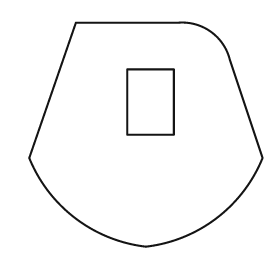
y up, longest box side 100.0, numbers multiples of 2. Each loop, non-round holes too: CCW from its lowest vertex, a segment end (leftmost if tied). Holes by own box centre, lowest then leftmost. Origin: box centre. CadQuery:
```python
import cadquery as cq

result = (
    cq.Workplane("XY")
    .moveTo(0.0, -48.0)
    .threePointArc((30.0, -36.0), (50.0, -10.0))
    .lineTo(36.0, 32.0)
    .threePointArc((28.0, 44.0), (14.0, 48.0))
    .lineTo(-30.0, 48.0)
    .lineTo(-50.0, -10.0)
    .threePointArc((-30.0, -36.0), (0.0, -48.0))
    .close()
    .moveTo(-8.0, 0.0)
    .lineTo(12.0, 0.0)
    .lineTo(12.0, 28.0)
    .lineTo(-8.0, 28.0)
    .close()
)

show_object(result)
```